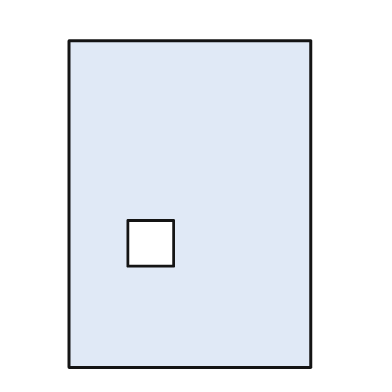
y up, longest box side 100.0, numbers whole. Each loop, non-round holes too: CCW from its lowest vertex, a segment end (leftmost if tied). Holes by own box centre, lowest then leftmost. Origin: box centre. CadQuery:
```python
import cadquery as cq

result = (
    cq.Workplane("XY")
    .moveTo(-37.0, -50.0)
    .lineTo(37.0, -50.0)
    .lineTo(37.0, 50.0)
    .lineTo(-37.0, 50.0)
    .close()
    .moveTo(-19.0, -19.0)
    .lineTo(-5.0, -19.0)
    .lineTo(-5.0, -5.0)
    .lineTo(-19.0, -5.0)
    .close()
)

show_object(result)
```